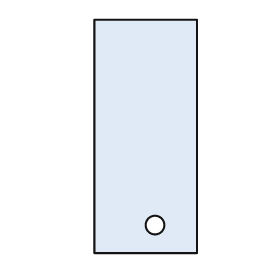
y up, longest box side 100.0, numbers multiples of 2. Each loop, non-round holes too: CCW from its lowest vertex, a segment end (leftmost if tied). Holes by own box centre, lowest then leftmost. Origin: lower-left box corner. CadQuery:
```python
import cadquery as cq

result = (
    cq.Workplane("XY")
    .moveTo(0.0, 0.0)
    .lineTo(44.0, 0.0)
    .lineTo(44.0, 100.0)
    .lineTo(0.0, 100.0)
    .close()
    .moveTo(26.0, 12.0)
    .circle(4.0)
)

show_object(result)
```